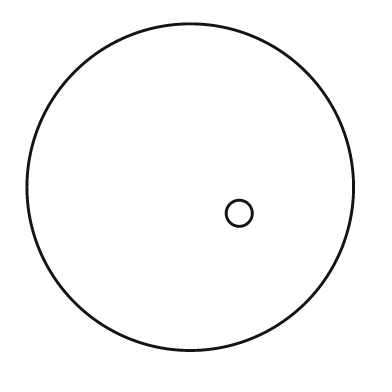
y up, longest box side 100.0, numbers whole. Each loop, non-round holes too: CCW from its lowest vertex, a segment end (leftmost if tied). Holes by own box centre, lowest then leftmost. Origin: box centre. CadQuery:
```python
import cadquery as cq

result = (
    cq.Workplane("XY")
    .moveTo(0.0, 0.0)
    .circle(50.0)
    .moveTo(15.0, -8.0)
    .circle(4.0)
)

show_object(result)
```